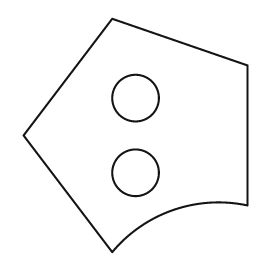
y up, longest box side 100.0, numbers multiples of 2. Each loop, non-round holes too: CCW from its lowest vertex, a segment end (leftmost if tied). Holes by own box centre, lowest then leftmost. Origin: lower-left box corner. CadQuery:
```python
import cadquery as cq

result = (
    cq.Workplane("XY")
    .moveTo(38.0, 0.0)
    .threePointArc((64.0, 18.0), (96.0, 20.0))
    .lineTo(96.0, 80.0)
    .lineTo(38.0, 100.0)
    .lineTo(0.0, 50.0)
    .close()
    .moveTo(48.0, 34.0)
    .circle(10.0)
    .moveTo(48.0, 66.0)
    .circle(10.0)
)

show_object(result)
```